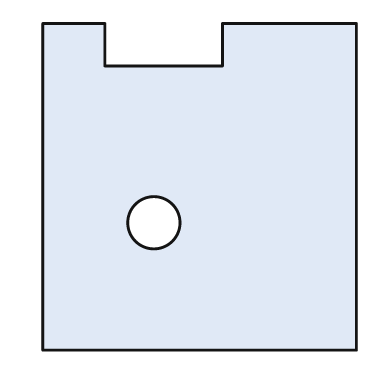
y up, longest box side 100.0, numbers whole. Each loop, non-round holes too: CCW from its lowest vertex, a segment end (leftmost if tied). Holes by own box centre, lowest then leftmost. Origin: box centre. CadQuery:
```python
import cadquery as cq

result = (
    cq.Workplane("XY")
    .moveTo(-48.0, -50.0)
    .lineTo(48.0, -50.0)
    .lineTo(48.0, 50.0)
    .lineTo(7.0, 50.0)
    .lineTo(7.0, 37.0)
    .lineTo(-29.0, 37.0)
    .lineTo(-29.0, 50.0)
    .lineTo(-48.0, 50.0)
    .close()
    .moveTo(-14.0, -11.0)
    .circle(8.0)
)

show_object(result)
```